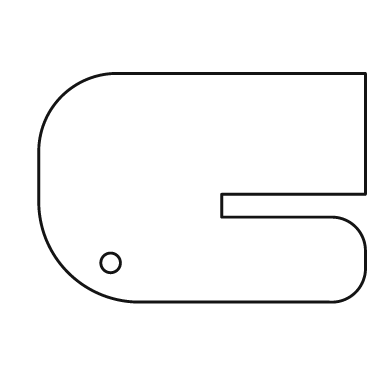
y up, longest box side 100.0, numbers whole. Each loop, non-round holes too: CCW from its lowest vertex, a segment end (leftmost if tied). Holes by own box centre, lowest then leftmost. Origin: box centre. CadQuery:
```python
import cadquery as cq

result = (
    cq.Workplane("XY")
    .moveTo(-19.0, -35.0)
    .lineTo(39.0, -35.0)
    .threePointArc((47.0, -32.0), (50.0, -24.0))
    .lineTo(50.0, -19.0)
    .threePointArc((47.0, -12.0), (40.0, -9.0))
    .lineTo(6.0, -9.0)
    .lineTo(6.0, -2.0)
    .lineTo(50.0, -2.0)
    .lineTo(50.0, 35.0)
    .lineTo(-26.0, 35.0)
    .threePointArc((-43.0, 28.0), (-50.0, 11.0))
    .lineTo(-50.0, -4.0)
    .threePointArc((-41.0, -26.0), (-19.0, -35.0))
    .close()
    .moveTo(-28.0, -23.0)
    .circle(3.0)
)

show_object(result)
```